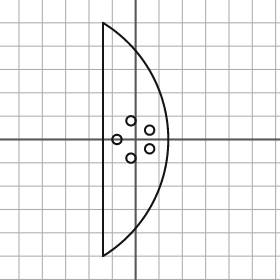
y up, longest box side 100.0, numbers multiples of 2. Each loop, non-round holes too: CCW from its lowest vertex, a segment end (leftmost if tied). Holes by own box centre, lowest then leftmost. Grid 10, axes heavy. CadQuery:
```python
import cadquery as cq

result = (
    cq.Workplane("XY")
    .moveTo(-14.0, -50.0)
    .threePointArc((14.0, 0.0), (-14.0, 50.0))
    .close()
    .moveTo(-2.0, -8.0)
    .circle(2.0)
    .moveTo(6.0, -4.0)
    .circle(2.0)
    .moveTo(-8.0, 0.0)
    .circle(2.0)
    .moveTo(6.0, 4.0)
    .circle(2.0)
    .moveTo(-2.0, 8.0)
    .circle(2.0)
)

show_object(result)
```